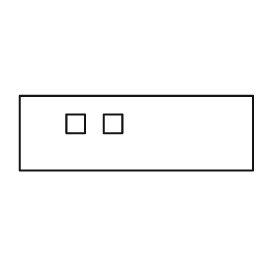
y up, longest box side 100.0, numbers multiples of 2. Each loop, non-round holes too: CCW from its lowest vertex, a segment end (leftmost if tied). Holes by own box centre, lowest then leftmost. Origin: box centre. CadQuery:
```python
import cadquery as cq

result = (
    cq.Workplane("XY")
    .moveTo(-50.0, -16.0)
    .lineTo(50.0, -16.0)
    .lineTo(50.0, 16.0)
    .lineTo(-50.0, 16.0)
    .close()
    .moveTo(-30.0, 0.0)
    .lineTo(-22.0, 0.0)
    .lineTo(-22.0, 8.0)
    .lineTo(-30.0, 8.0)
    .close()
    .moveTo(-14.0, 0.0)
    .lineTo(-6.0, 0.0)
    .lineTo(-6.0, 8.0)
    .lineTo(-14.0, 8.0)
    .close()
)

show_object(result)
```